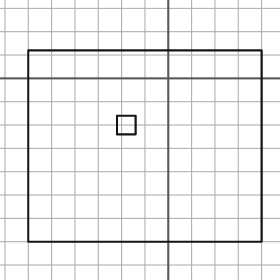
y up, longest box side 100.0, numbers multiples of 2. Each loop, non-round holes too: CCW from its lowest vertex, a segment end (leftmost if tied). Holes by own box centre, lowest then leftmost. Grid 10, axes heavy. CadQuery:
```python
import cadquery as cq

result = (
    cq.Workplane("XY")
    .moveTo(-60.0, -70.0)
    .lineTo(40.0, -70.0)
    .lineTo(40.0, 12.0)
    .lineTo(-60.0, 12.0)
    .close()
    .moveTo(-22.0, -24.0)
    .lineTo(-14.0, -24.0)
    .lineTo(-14.0, -16.0)
    .lineTo(-22.0, -16.0)
    .close()
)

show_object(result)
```